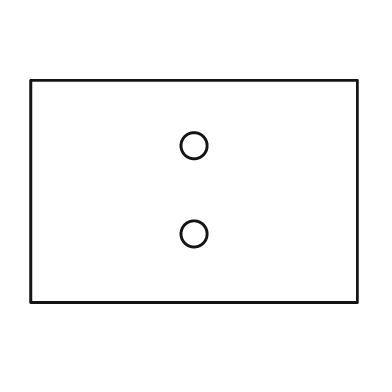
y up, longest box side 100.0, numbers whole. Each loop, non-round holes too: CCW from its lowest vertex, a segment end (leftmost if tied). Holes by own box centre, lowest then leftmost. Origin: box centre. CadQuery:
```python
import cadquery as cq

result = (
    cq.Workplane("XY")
    .moveTo(-50.0, -34.0)
    .lineTo(50.0, -34.0)
    .lineTo(50.0, 34.0)
    .lineTo(-50.0, 34.0)
    .close()
    .moveTo(0.0, -13.0)
    .circle(4.0)
    .moveTo(0.0, 14.0)
    .circle(4.0)
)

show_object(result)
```